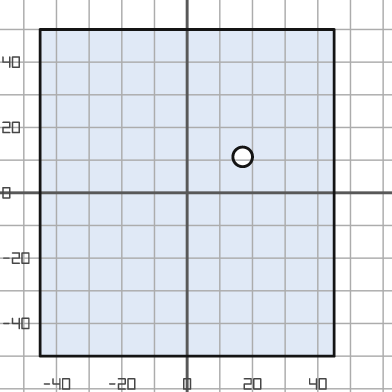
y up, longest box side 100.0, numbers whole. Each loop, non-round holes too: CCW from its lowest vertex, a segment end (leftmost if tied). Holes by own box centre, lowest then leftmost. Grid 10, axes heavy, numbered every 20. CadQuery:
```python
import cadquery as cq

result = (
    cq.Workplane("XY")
    .moveTo(-45.0, -50.0)
    .lineTo(45.0, -50.0)
    .lineTo(45.0, 50.0)
    .lineTo(-45.0, 50.0)
    .close()
    .moveTo(17.0, 11.0)
    .circle(3.0)
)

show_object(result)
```